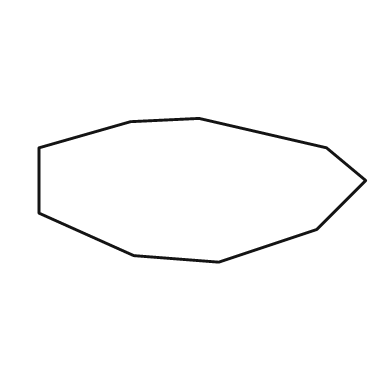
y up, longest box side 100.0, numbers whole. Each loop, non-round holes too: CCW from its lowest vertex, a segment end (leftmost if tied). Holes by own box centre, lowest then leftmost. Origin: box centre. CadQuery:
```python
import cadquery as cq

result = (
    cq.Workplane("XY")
    .moveTo(5.0, -22.0)
    .lineTo(35.0, -12.0)
    .lineTo(50.0, 3.0)
    .lineTo(38.0, 13.0)
    .lineTo(-1.0, 22.0)
    .lineTo(-22.0, 21.0)
    .lineTo(-50.0, 13.0)
    .lineTo(-50.0, -7.0)
    .lineTo(-21.0, -20.0)
    .close()
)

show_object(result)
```